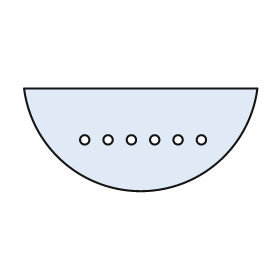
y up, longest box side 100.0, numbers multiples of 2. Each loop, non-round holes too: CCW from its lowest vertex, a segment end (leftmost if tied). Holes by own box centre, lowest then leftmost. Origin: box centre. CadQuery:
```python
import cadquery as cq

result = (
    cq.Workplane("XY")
    .moveTo(-50.0, 22.0)
    .threePointArc((0.0, -22.0), (50.0, 22.0))
    .close()
    .moveTo(-24.0, 0.0)
    .circle(2.0)
    .moveTo(-14.0, 0.0)
    .circle(2.0)
    .moveTo(-4.0, 0.0)
    .circle(2.0)
    .moveTo(6.0, 0.0)
    .circle(2.0)
    .moveTo(16.0, 0.0)
    .circle(2.0)
    .moveTo(26.0, 0.0)
    .circle(2.0)
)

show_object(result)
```